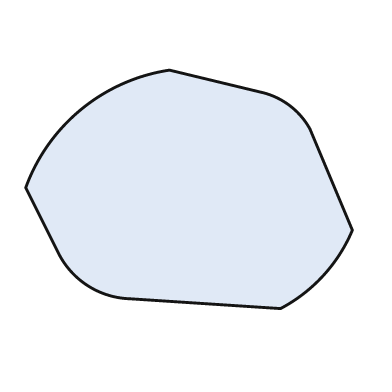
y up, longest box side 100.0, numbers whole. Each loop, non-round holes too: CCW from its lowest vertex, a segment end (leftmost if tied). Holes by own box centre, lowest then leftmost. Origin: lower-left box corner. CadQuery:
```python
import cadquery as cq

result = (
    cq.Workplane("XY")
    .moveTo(78.0, 0.0)
    .threePointArc((91.0, 10.0), (100.0, 24.0))
    .lineTo(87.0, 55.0)
    .threePointArc((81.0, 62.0), (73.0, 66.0))
    .lineTo(44.0, 73.0)
    .threePointArc((17.0, 61.0), (0.0, 37.0))
    .lineTo(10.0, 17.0)
    .threePointArc((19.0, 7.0), (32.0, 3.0))
    .close()
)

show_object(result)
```